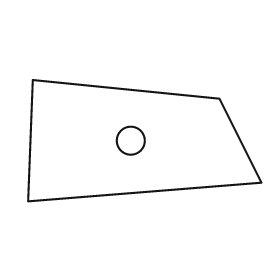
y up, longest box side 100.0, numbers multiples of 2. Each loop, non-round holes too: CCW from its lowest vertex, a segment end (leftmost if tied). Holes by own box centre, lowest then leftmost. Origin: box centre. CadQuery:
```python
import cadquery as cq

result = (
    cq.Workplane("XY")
    .moveTo(-50.0, -26.0)
    .lineTo(50.0, -18.0)
    .lineTo(32.0, 18.0)
    .lineTo(-48.0, 26.0)
    .close()
    .moveTo(-6.0, 0.0)
    .circle(6.0)
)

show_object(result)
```